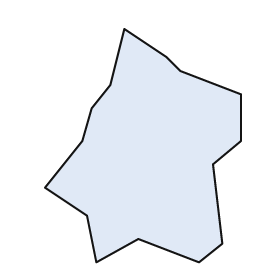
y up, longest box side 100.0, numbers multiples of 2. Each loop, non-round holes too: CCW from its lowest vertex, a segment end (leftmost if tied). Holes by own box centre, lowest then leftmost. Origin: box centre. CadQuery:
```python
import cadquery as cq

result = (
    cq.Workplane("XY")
    .moveTo(-20.0, -50.0)
    .lineTo(-2.0, -40.0)
    .lineTo(24.0, -50.0)
    .lineTo(34.0, -42.0)
    .lineTo(30.0, -8.0)
    .lineTo(42.0, 2.0)
    .lineTo(42.0, 22.0)
    .lineTo(16.0, 32.0)
    .lineTo(10.0, 38.0)
    .lineTo(-8.0, 50.0)
    .lineTo(-14.0, 26.0)
    .lineTo(-22.0, 16.0)
    .lineTo(-26.0, 2.0)
    .lineTo(-42.0, -18.0)
    .lineTo(-24.0, -30.0)
    .close()
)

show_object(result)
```